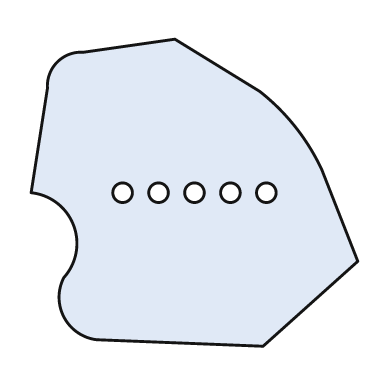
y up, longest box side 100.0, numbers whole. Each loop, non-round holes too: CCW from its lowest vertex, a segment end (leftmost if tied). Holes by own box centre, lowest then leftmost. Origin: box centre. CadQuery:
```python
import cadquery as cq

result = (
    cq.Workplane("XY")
    .moveTo(21.0, -47.0)
    .lineTo(50.0, -21.0)
    .lineTo(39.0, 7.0)
    .threePointArc((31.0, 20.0), (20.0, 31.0))
    .lineTo(-6.0, 47.0)
    .lineTo(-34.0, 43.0)
    .threePointArc((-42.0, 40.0), (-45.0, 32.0))
    .lineTo(-50.0, 0.0)
    .threePointArc((-37.0, -10.0), (-40.0, -26.0))
    .threePointArc((-40.0, -38.0), (-30.0, -45.0))
    .close()
    .moveTo(-22.0, 0.0)
    .circle(3.0)
    .moveTo(-11.0, 0.0)
    .circle(3.0)
    .moveTo(0.0, 0.0)
    .circle(3.0)
    .moveTo(11.0, 0.0)
    .circle(3.0)
    .moveTo(22.0, 0.0)
    .circle(3.0)
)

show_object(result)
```